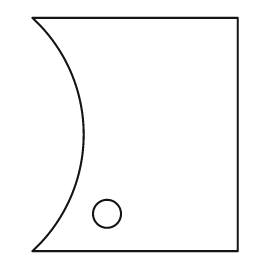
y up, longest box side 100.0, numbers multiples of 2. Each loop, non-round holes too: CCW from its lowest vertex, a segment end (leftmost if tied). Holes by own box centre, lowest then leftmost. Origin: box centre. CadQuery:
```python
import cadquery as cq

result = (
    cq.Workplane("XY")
    .moveTo(-44.0, -50.0)
    .lineTo(44.0, -50.0)
    .lineTo(44.0, 50.0)
    .lineTo(-44.0, 50.0)
    .threePointArc((-22.0, 0.0), (-44.0, -50.0))
    .close()
    .moveTo(-12.0, -34.0)
    .circle(6.0)
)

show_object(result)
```